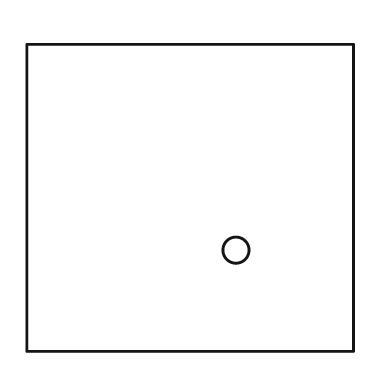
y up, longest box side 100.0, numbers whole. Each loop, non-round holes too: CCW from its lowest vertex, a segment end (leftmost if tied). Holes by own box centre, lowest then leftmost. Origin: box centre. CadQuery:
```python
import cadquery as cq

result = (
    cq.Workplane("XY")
    .moveTo(-50.0, -47.0)
    .lineTo(50.0, -47.0)
    .lineTo(50.0, 47.0)
    .lineTo(-50.0, 47.0)
    .close()
    .moveTo(14.0, -16.0)
    .circle(4.0)
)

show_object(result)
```